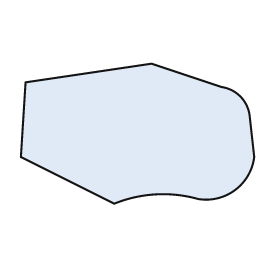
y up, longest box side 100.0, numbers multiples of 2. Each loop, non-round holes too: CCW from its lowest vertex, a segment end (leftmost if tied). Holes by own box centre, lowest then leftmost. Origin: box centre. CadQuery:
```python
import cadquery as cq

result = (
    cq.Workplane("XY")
    .moveTo(-10.0, -30.0)
    .threePointArc((8.0, -26.0), (26.0, -28.0))
    .threePointArc((42.0, -24.0), (50.0, -10.0))
    .lineTo(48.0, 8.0)
    .threePointArc((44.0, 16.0), (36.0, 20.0))
    .lineTo(6.0, 30.0)
    .lineTo(-48.0, 22.0)
    .lineTo(-50.0, -10.0)
    .close()
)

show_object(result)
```